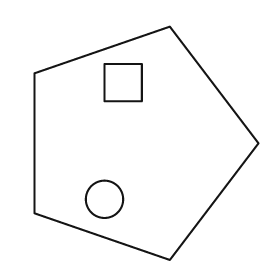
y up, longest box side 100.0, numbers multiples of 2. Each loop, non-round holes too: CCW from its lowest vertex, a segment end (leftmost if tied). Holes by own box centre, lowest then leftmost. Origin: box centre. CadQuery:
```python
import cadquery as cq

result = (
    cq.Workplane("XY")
    .moveTo(10.0, -50.0)
    .lineTo(48.0, 0.0)
    .lineTo(10.0, 50.0)
    .lineTo(-48.0, 30.0)
    .lineTo(-48.0, -30.0)
    .close()
    .moveTo(-18.0, -24.0)
    .circle(8.0)
    .moveTo(-18.0, 18.0)
    .lineTo(-2.0, 18.0)
    .lineTo(-2.0, 34.0)
    .lineTo(-18.0, 34.0)
    .close()
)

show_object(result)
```